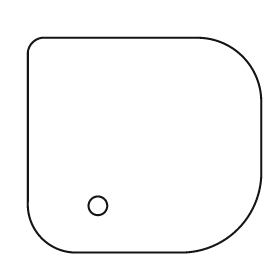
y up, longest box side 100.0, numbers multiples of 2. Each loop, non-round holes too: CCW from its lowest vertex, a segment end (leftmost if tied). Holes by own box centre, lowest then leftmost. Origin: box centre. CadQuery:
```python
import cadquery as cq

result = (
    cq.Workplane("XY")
    .moveTo(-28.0, -46.0)
    .lineTo(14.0, -46.0)
    .threePointArc((40.0, -36.0), (50.0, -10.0))
    .lineTo(50.0, 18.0)
    .threePointArc((42.0, 38.0), (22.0, 46.0))
    .lineTo(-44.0, 46.0)
    .threePointArc((-48.0, 44.0), (-50.0, 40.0))
    .lineTo(-50.0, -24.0)
    .threePointArc((-44.0, -40.0), (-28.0, -46.0))
    .close()
    .moveTo(-20.0, -26.0)
    .circle(4.0)
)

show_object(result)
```